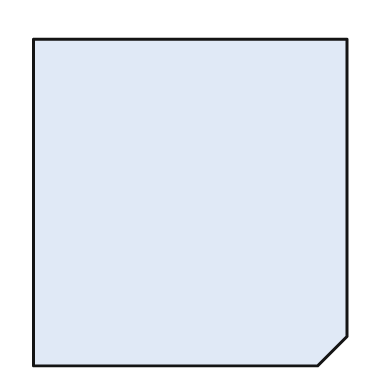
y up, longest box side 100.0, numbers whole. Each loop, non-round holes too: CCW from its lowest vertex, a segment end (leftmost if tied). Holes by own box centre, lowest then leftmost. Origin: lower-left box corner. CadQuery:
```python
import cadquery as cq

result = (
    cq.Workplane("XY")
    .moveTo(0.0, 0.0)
    .lineTo(87.0, 0.0)
    .lineTo(96.0, 9.0)
    .lineTo(96.0, 100.0)
    .lineTo(0.0, 100.0)
    .close()
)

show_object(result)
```